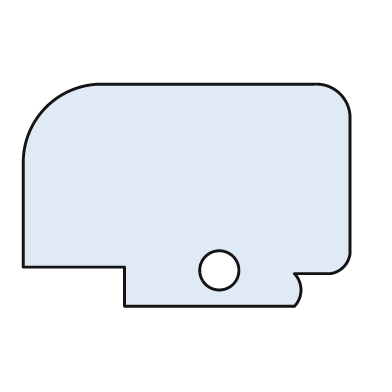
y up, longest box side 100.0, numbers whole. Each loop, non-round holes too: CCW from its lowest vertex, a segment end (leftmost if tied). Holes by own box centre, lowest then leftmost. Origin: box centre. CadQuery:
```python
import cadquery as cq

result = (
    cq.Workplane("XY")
    .moveTo(-19.0, -34.0)
    .lineTo(33.0, -34.0)
    .threePointArc((35.0, -29.0), (33.0, -24.0))
    .lineTo(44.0, -24.0)
    .threePointArc((48.0, -22.0), (50.0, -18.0))
    .lineTo(50.0, 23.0)
    .threePointArc((47.0, 31.0), (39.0, 34.0))
    .lineTo(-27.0, 34.0)
    .threePointArc((-43.0, 27.0), (-50.0, 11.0))
    .lineTo(-50.0, -22.0)
    .lineTo(-19.0, -22.0)
    .close()
    .moveTo(10.0, -23.0)
    .circle(6.0)
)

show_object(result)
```